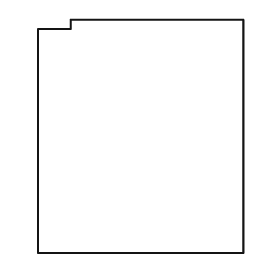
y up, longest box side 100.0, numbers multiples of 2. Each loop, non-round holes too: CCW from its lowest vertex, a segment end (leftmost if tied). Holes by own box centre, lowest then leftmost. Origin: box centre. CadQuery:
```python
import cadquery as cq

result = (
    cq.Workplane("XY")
    .moveTo(-44.0, -50.0)
    .lineTo(44.0, -50.0)
    .lineTo(44.0, 50.0)
    .lineTo(-30.0, 50.0)
    .lineTo(-30.0, 46.0)
    .lineTo(-44.0, 46.0)
    .close()
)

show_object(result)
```